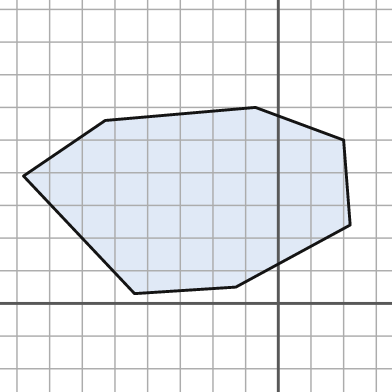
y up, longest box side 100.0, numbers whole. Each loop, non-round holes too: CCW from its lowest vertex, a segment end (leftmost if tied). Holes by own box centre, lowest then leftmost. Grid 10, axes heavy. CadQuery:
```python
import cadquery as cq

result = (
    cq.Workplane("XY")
    .moveTo(-44.0, 3.0)
    .lineTo(-13.0, 5.0)
    .lineTo(22.0, 24.0)
    .lineTo(20.0, 50.0)
    .lineTo(-7.0, 60.0)
    .lineTo(-53.0, 56.0)
    .lineTo(-78.0, 39.0)
    .close()
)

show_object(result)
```